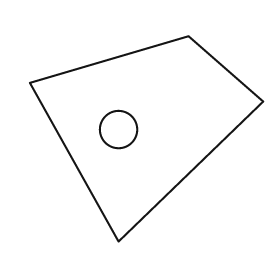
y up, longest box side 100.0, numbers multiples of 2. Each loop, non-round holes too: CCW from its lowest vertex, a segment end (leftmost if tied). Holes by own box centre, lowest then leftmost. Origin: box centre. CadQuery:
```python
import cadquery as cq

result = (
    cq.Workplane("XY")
    .moveTo(-12.0, -44.0)
    .lineTo(50.0, 16.0)
    .lineTo(18.0, 44.0)
    .lineTo(-50.0, 24.0)
    .close()
    .moveTo(-12.0, 4.0)
    .circle(8.0)
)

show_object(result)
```